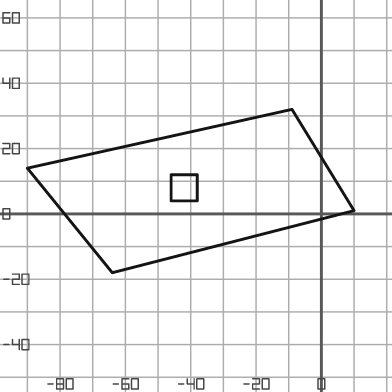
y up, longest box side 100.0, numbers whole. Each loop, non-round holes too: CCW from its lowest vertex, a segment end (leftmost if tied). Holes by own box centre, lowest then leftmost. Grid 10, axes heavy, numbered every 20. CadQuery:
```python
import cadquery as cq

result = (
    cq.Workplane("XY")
    .moveTo(-64.0, -18.0)
    .lineTo(10.0, 1.0)
    .lineTo(-9.0, 32.0)
    .lineTo(-90.0, 14.0)
    .close()
    .moveTo(-46.0, 4.0)
    .lineTo(-38.0, 4.0)
    .lineTo(-38.0, 12.0)
    .lineTo(-46.0, 12.0)
    .close()
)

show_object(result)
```